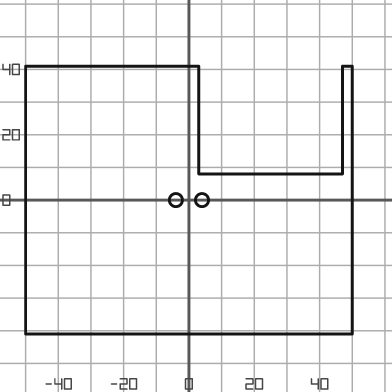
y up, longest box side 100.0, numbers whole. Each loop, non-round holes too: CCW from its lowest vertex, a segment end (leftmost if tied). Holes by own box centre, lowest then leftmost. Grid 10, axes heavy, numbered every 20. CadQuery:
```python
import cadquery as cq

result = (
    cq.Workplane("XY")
    .moveTo(-50.0, -41.0)
    .lineTo(50.0, -41.0)
    .lineTo(50.0, 41.0)
    .lineTo(47.0, 41.0)
    .lineTo(47.0, 8.0)
    .lineTo(3.0, 8.0)
    .lineTo(3.0, 41.0)
    .lineTo(-50.0, 41.0)
    .close()
    .moveTo(-4.0, 0.0)
    .circle(2.0)
    .moveTo(4.0, 0.0)
    .circle(2.0)
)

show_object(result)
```